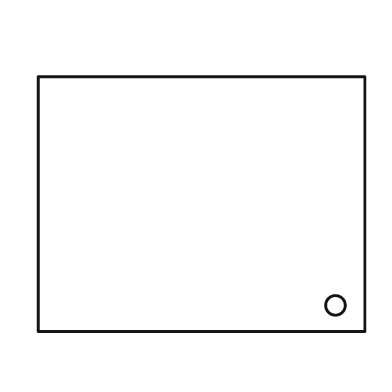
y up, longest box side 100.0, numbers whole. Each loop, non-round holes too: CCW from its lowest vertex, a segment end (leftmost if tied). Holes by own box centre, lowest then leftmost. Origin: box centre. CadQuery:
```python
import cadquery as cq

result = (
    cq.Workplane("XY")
    .moveTo(-50.0, -39.0)
    .lineTo(50.0, -39.0)
    .lineTo(50.0, 39.0)
    .lineTo(-50.0, 39.0)
    .close()
    .moveTo(41.0, -31.0)
    .circle(3.0)
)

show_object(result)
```